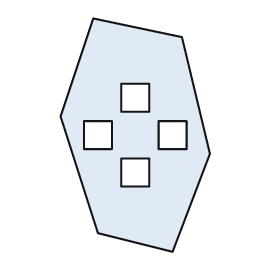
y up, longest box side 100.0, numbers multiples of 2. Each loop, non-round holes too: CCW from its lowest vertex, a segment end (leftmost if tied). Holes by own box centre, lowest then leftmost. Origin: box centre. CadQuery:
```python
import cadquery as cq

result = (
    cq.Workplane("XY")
    .moveTo(16.0, -50.0)
    .lineTo(32.0, -8.0)
    .lineTo(20.0, 42.0)
    .lineTo(-18.0, 50.0)
    .lineTo(-32.0, 8.0)
    .lineTo(-16.0, -42.0)
    .close()
    .moveTo(-6.0, -22.0)
    .lineTo(6.0, -22.0)
    .lineTo(6.0, -10.0)
    .lineTo(-6.0, -10.0)
    .close()
    .moveTo(-22.0, -6.0)
    .lineTo(-10.0, -6.0)
    .lineTo(-10.0, 6.0)
    .lineTo(-22.0, 6.0)
    .close()
    .moveTo(10.0, -6.0)
    .lineTo(22.0, -6.0)
    .lineTo(22.0, 6.0)
    .lineTo(10.0, 6.0)
    .close()
    .moveTo(-6.0, 10.0)
    .lineTo(6.0, 10.0)
    .lineTo(6.0, 22.0)
    .lineTo(-6.0, 22.0)
    .close()
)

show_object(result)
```